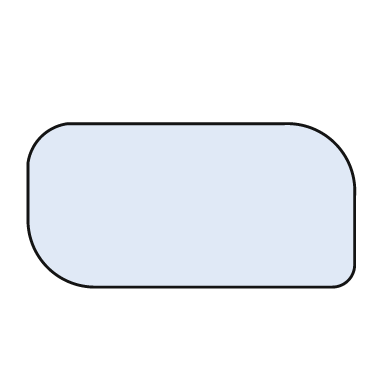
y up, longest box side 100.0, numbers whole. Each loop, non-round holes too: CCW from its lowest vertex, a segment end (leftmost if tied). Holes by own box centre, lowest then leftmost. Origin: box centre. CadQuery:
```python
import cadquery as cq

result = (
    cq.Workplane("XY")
    .moveTo(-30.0, -25.0)
    .lineTo(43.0, -25.0)
    .threePointArc((48.0, -23.0), (50.0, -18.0))
    .lineTo(50.0, 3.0)
    .threePointArc((44.0, 19.0), (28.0, 25.0))
    .lineTo(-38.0, 25.0)
    .threePointArc((-46.0, 21.0), (-50.0, 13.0))
    .lineTo(-50.0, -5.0)
    .threePointArc((-44.0, -19.0), (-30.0, -25.0))
    .close()
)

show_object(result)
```